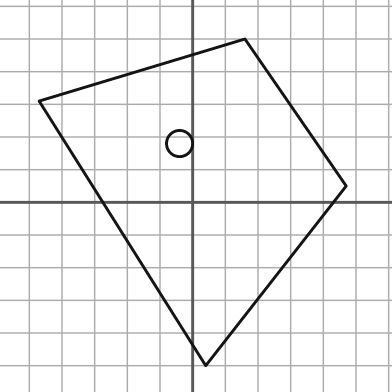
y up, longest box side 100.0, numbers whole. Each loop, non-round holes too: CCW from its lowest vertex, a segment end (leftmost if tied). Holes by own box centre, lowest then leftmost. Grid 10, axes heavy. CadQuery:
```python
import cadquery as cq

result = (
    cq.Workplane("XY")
    .moveTo(4.0, -50.0)
    .lineTo(47.0, 5.0)
    .lineTo(16.0, 50.0)
    .lineTo(-47.0, 31.0)
    .close()
    .moveTo(-4.0, 18.0)
    .circle(4.0)
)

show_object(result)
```